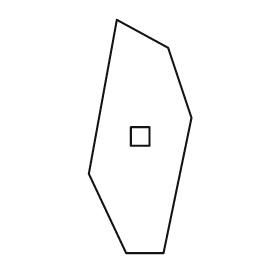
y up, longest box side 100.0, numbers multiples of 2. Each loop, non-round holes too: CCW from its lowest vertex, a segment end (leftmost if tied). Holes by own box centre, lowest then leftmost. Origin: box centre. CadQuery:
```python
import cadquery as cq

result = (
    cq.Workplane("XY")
    .moveTo(-6.0, -50.0)
    .lineTo(10.0, -50.0)
    .lineTo(22.0, 8.0)
    .lineTo(12.0, 38.0)
    .lineTo(-10.0, 50.0)
    .lineTo(-22.0, -16.0)
    .close()
    .moveTo(-4.0, -4.0)
    .lineTo(4.0, -4.0)
    .lineTo(4.0, 4.0)
    .lineTo(-4.0, 4.0)
    .close()
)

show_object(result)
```